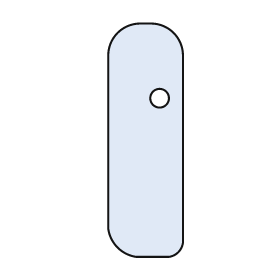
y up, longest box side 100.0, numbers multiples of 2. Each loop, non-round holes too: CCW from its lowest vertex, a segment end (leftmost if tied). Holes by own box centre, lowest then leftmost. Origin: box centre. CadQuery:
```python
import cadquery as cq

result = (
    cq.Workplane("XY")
    .moveTo(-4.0, -50.0)
    .lineTo(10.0, -50.0)
    .threePointArc((14.0, -48.0), (16.0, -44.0))
    .lineTo(16.0, 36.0)
    .threePointArc((12.0, 46.0), (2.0, 50.0))
    .lineTo(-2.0, 50.0)
    .threePointArc((-12.0, 46.0), (-16.0, 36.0))
    .lineTo(-16.0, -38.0)
    .threePointArc((-12.0, -46.0), (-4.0, -50.0))
    .close()
    .moveTo(6.0, 18.0)
    .circle(4.0)
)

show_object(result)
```